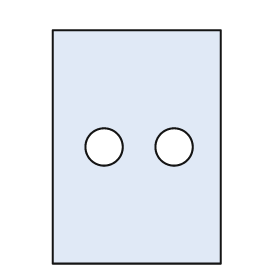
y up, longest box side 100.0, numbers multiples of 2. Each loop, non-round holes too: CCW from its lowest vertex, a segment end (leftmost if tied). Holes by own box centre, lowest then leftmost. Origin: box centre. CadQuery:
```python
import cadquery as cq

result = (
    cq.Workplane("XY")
    .moveTo(-36.0, -50.0)
    .lineTo(36.0, -50.0)
    .lineTo(36.0, 50.0)
    .lineTo(-36.0, 50.0)
    .close()
    .moveTo(-14.0, 0.0)
    .circle(8.0)
    .moveTo(16.0, 0.0)
    .circle(8.0)
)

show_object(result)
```